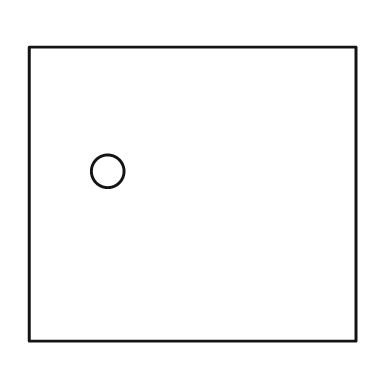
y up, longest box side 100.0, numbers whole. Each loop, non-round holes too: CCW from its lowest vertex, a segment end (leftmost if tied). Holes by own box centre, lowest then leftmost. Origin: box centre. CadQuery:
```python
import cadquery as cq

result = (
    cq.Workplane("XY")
    .moveTo(-50.0, -45.0)
    .lineTo(50.0, -45.0)
    .lineTo(50.0, 45.0)
    .lineTo(-50.0, 45.0)
    .close()
    .moveTo(-26.0, 7.0)
    .circle(5.0)
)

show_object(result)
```